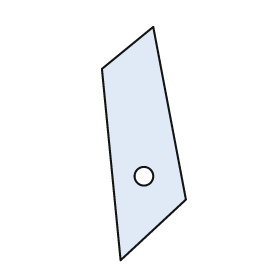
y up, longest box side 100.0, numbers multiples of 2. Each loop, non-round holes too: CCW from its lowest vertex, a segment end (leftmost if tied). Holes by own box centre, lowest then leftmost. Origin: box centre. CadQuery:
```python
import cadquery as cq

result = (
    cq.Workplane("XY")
    .moveTo(-10.0, -50.0)
    .lineTo(18.0, -24.0)
    .lineTo(4.0, 50.0)
    .lineTo(-18.0, 32.0)
    .close()
    .moveTo(0.0, -14.0)
    .circle(4.0)
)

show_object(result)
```